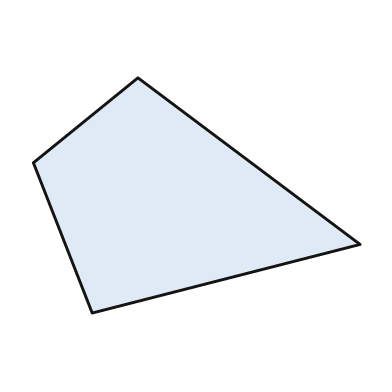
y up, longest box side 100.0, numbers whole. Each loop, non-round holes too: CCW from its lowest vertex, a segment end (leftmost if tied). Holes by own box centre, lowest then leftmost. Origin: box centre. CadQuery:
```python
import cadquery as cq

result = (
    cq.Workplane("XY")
    .moveTo(-32.0, -36.0)
    .lineTo(50.0, -15.0)
    .lineTo(-18.0, 36.0)
    .lineTo(-50.0, 10.0)
    .close()
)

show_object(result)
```